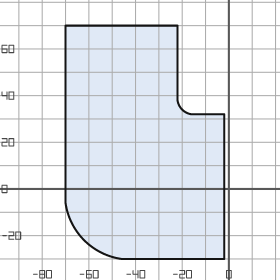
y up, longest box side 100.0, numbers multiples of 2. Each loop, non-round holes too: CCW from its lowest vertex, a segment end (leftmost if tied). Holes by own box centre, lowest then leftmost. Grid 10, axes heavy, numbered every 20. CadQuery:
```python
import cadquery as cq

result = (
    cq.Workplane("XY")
    .moveTo(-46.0, -30.0)
    .lineTo(-2.0, -30.0)
    .lineTo(-2.0, 32.0)
    .lineTo(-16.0, 32.0)
    .threePointArc((-20.0, 34.0), (-22.0, 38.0))
    .lineTo(-22.0, 70.0)
    .lineTo(-70.0, 70.0)
    .lineTo(-70.0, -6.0)
    .threePointArc((-62.0, -22.0), (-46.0, -30.0))
    .close()
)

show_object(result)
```